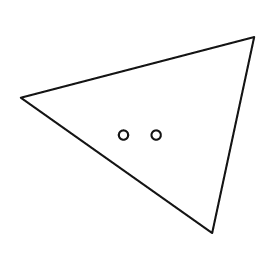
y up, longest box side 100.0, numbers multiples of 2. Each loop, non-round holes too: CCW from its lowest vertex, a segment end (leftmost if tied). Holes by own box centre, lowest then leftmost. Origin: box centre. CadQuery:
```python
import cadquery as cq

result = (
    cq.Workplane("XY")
    .moveTo(32.0, -42.0)
    .lineTo(50.0, 42.0)
    .lineTo(-50.0, 16.0)
    .close()
    .moveTo(-6.0, 0.0)
    .circle(2.0)
    .moveTo(8.0, 0.0)
    .circle(2.0)
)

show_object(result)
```